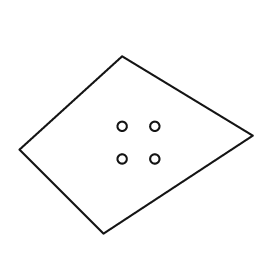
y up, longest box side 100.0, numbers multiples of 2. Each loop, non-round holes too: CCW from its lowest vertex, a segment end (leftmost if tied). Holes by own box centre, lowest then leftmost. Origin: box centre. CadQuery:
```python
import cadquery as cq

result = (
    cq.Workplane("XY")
    .moveTo(-14.0, -38.0)
    .lineTo(50.0, 4.0)
    .lineTo(-6.0, 38.0)
    .lineTo(-50.0, -2.0)
    .close()
    .moveTo(-6.0, -6.0)
    .circle(2.0)
    .moveTo(8.0, -6.0)
    .circle(2.0)
    .moveTo(-6.0, 8.0)
    .circle(2.0)
    .moveTo(8.0, 8.0)
    .circle(2.0)
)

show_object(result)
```